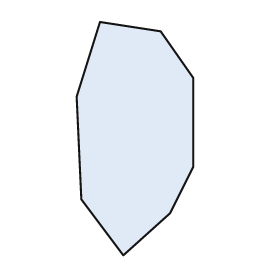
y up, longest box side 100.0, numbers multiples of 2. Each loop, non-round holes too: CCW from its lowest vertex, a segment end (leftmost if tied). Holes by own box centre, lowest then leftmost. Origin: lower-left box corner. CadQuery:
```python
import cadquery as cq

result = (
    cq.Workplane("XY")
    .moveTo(20.0, 0.0)
    .lineTo(40.0, 18.0)
    .lineTo(50.0, 38.0)
    .lineTo(50.0, 76.0)
    .lineTo(36.0, 96.0)
    .lineTo(10.0, 100.0)
    .lineTo(0.0, 68.0)
    .lineTo(2.0, 24.0)
    .close()
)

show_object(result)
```